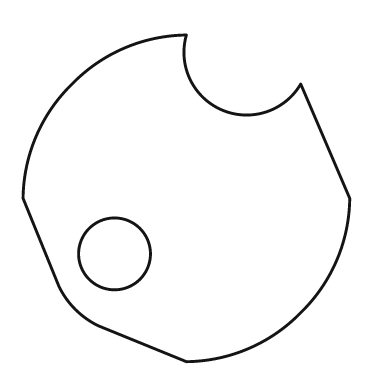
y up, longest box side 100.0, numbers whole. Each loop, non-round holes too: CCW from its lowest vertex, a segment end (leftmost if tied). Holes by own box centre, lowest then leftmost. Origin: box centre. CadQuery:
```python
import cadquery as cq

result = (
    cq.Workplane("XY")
    .moveTo(0.0, -50.0)
    .threePointArc((19.0, -46.0), (35.0, -35.0))
    .threePointArc((46.0, -19.0), (50.0, 0.0))
    .lineTo(35.0, 35.0)
    .threePointArc((11.0, 27.0), (0.0, 50.0))
    .threePointArc((-19.0, 46.0), (-35.0, 35.0))
    .threePointArc((-46.0, 19.0), (-50.0, 0.0))
    .lineTo(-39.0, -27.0)
    .threePointArc((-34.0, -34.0), (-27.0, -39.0))
    .close()
    .moveTo(-22.0, -17.0)
    .circle(11.0)
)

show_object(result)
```